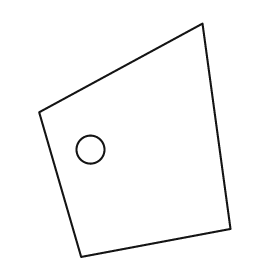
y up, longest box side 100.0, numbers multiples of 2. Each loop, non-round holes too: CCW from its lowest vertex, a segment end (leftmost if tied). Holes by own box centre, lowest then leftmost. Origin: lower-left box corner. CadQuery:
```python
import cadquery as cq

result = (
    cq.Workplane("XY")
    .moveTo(18.0, 0.0)
    .lineTo(82.0, 12.0)
    .lineTo(70.0, 100.0)
    .lineTo(0.0, 62.0)
    .close()
    .moveTo(22.0, 46.0)
    .circle(6.0)
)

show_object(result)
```